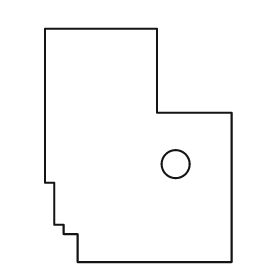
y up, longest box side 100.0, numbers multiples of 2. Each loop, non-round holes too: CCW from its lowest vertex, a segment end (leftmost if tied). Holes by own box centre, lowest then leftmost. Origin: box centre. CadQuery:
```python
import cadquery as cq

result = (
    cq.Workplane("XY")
    .moveTo(-26.0, -50.0)
    .lineTo(40.0, -50.0)
    .lineTo(40.0, 14.0)
    .lineTo(8.0, 14.0)
    .lineTo(8.0, 50.0)
    .lineTo(-40.0, 50.0)
    .lineTo(-40.0, -16.0)
    .lineTo(-36.0, -16.0)
    .lineTo(-36.0, -34.0)
    .lineTo(-32.0, -34.0)
    .lineTo(-32.0, -38.0)
    .lineTo(-26.0, -38.0)
    .close()
    .moveTo(16.0, -8.0)
    .circle(6.0)
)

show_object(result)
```